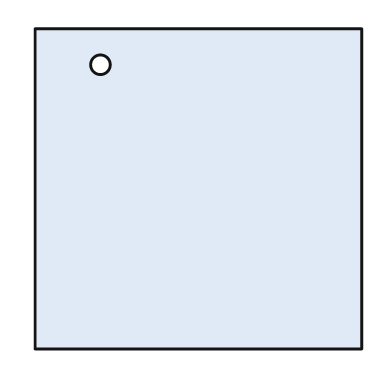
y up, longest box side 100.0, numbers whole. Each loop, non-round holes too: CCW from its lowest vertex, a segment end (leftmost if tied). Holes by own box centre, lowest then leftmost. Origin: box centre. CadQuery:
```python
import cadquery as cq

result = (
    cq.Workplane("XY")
    .moveTo(-50.0, -49.0)
    .lineTo(50.0, -49.0)
    .lineTo(50.0, 49.0)
    .lineTo(-50.0, 49.0)
    .close()
    .moveTo(-30.0, 38.0)
    .circle(3.0)
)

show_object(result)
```